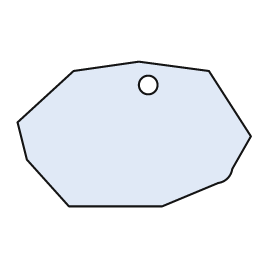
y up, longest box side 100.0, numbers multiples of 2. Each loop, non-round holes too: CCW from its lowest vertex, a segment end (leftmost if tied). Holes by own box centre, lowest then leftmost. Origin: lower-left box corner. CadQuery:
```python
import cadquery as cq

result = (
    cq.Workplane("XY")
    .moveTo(22.0, 0.0)
    .lineTo(62.0, 0.0)
    .lineTo(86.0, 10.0)
    .threePointArc((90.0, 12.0), (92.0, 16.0))
    .lineTo(100.0, 30.0)
    .lineTo(82.0, 58.0)
    .lineTo(52.0, 62.0)
    .lineTo(24.0, 58.0)
    .lineTo(0.0, 36.0)
    .lineTo(4.0, 20.0)
    .close()
    .moveTo(56.0, 52.0)
    .circle(4.0)
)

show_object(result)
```